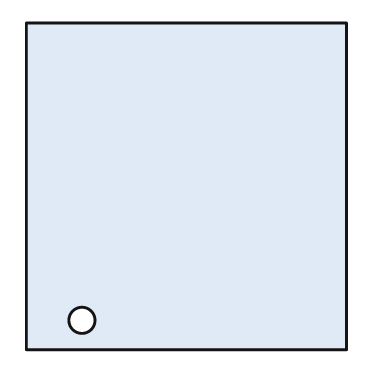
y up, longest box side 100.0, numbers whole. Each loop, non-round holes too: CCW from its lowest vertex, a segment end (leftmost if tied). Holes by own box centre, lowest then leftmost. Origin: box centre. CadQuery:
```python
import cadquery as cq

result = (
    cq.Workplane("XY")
    .moveTo(-49.0, -50.0)
    .lineTo(49.0, -50.0)
    .lineTo(49.0, 50.0)
    .lineTo(-49.0, 50.0)
    .close()
    .moveTo(-32.0, -41.0)
    .circle(4.0)
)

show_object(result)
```